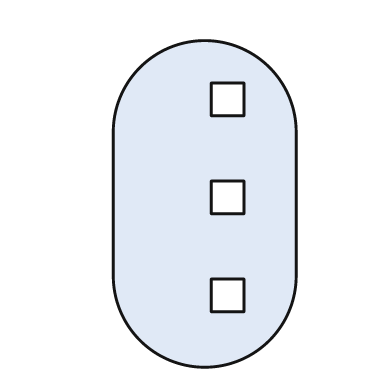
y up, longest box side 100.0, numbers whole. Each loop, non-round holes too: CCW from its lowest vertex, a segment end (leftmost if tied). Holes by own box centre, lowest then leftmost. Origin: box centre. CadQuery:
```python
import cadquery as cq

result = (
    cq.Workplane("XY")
    .moveTo(-28.0, -22.0)
    .threePointArc((0.0, -50.0), (28.0, -22.0))
    .lineTo(28.0, 22.0)
    .threePointArc((0.0, 50.0), (-28.0, 22.0))
    .close()
    .moveTo(2.0, -33.0)
    .lineTo(12.0, -33.0)
    .lineTo(12.0, -23.0)
    .lineTo(2.0, -23.0)
    .close()
    .moveTo(2.0, -3.0)
    .lineTo(12.0, -3.0)
    .lineTo(12.0, 7.0)
    .lineTo(2.0, 7.0)
    .close()
    .moveTo(2.0, 27.0)
    .lineTo(12.0, 27.0)
    .lineTo(12.0, 37.0)
    .lineTo(2.0, 37.0)
    .close()
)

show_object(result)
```